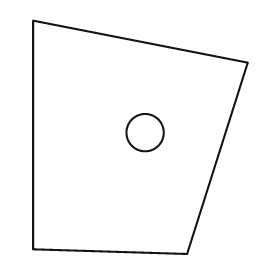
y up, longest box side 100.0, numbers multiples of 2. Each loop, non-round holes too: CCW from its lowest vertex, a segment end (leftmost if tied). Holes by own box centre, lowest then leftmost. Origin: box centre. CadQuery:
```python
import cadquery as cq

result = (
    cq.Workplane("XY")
    .moveTo(20.0, -50.0)
    .lineTo(46.0, 32.0)
    .lineTo(-46.0, 50.0)
    .lineTo(-46.0, -48.0)
    .close()
    .moveTo(2.0, 2.0)
    .circle(8.0)
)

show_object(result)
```